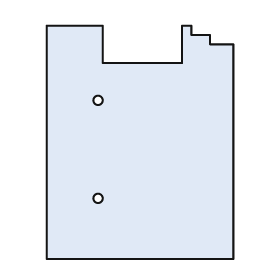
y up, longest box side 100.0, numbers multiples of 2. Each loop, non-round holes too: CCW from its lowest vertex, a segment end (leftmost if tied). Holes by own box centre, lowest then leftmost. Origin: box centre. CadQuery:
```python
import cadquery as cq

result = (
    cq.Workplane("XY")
    .moveTo(-40.0, -50.0)
    .lineTo(40.0, -50.0)
    .lineTo(40.0, 42.0)
    .lineTo(30.0, 42.0)
    .lineTo(30.0, 46.0)
    .lineTo(22.0, 46.0)
    .lineTo(22.0, 50.0)
    .lineTo(18.0, 50.0)
    .lineTo(18.0, 34.0)
    .lineTo(-16.0, 34.0)
    .lineTo(-16.0, 50.0)
    .lineTo(-40.0, 50.0)
    .close()
    .moveTo(-18.0, -24.0)
    .circle(2.0)
    .moveTo(-18.0, 18.0)
    .circle(2.0)
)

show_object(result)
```